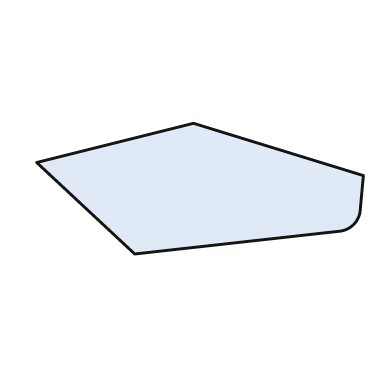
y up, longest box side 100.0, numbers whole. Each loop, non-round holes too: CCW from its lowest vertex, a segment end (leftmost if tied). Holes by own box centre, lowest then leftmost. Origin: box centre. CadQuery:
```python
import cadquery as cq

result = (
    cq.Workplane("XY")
    .moveTo(-20.0, -20.0)
    .lineTo(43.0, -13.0)
    .threePointArc((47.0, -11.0), (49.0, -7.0))
    .lineTo(50.0, 4.0)
    .lineTo(-2.0, 20.0)
    .lineTo(-50.0, 8.0)
    .close()
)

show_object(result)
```